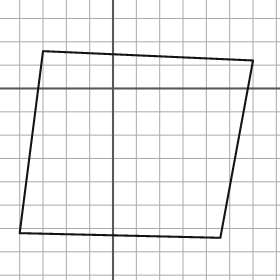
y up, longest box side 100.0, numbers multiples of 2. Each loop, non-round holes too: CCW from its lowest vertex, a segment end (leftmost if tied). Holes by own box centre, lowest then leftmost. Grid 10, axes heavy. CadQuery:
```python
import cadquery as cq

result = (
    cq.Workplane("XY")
    .moveTo(46.0, -64.0)
    .lineTo(60.0, 12.0)
    .lineTo(-30.0, 16.0)
    .lineTo(-40.0, -62.0)
    .close()
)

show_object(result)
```